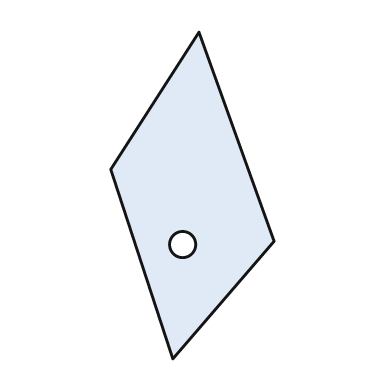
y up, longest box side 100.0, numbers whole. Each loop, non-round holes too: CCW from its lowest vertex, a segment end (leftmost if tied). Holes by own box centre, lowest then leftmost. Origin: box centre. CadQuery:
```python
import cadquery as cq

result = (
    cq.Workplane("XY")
    .moveTo(-6.0, -50.0)
    .lineTo(25.0, -14.0)
    .lineTo(2.0, 50.0)
    .lineTo(-25.0, 8.0)
    .close()
    .moveTo(-3.0, -15.0)
    .circle(4.0)
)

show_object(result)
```